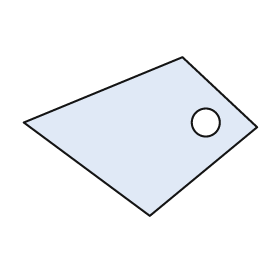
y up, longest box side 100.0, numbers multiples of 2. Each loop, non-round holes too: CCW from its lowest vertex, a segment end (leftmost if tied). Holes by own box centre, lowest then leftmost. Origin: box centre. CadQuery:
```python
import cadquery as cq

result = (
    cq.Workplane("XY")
    .moveTo(4.0, -34.0)
    .lineTo(50.0, 4.0)
    .lineTo(18.0, 34.0)
    .lineTo(-50.0, 6.0)
    .close()
    .moveTo(28.0, 6.0)
    .circle(6.0)
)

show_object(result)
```